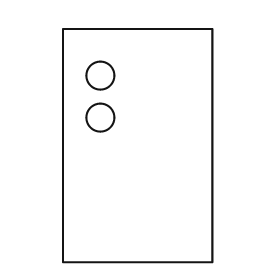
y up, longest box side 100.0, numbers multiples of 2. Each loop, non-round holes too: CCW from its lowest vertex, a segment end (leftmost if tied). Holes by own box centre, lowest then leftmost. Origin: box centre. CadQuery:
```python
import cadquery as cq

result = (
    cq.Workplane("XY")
    .moveTo(-32.0, -50.0)
    .lineTo(32.0, -50.0)
    .lineTo(32.0, 50.0)
    .lineTo(-32.0, 50.0)
    .close()
    .moveTo(-16.0, 12.0)
    .circle(6.0)
    .moveTo(-16.0, 30.0)
    .circle(6.0)
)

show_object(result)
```